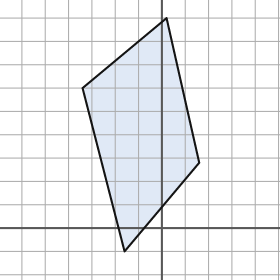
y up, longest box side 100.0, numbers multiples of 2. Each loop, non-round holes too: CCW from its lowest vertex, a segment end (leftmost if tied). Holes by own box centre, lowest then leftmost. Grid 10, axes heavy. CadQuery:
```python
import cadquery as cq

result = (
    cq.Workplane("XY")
    .moveTo(-16.0, -10.0)
    .lineTo(16.0, 28.0)
    .lineTo(2.0, 90.0)
    .lineTo(-34.0, 60.0)
    .close()
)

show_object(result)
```